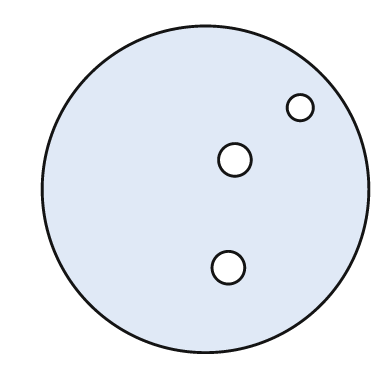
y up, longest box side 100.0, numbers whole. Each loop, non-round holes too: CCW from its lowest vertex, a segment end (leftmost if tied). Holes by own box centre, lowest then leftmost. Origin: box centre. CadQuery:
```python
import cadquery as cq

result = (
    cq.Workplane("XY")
    .moveTo(0.0, 0.0)
    .circle(50.0)
    .moveTo(7.0, -24.0)
    .circle(5.0)
    .moveTo(9.0, 9.0)
    .circle(5.0)
    .moveTo(29.0, 25.0)
    .circle(4.0)
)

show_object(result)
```